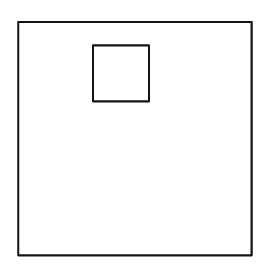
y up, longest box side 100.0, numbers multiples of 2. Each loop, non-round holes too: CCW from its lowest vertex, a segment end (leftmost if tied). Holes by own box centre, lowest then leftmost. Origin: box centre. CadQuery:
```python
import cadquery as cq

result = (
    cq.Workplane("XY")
    .moveTo(-50.0, -50.0)
    .lineTo(50.0, -50.0)
    .lineTo(50.0, 50.0)
    .lineTo(-50.0, 50.0)
    .close()
    .moveTo(-18.0, 16.0)
    .lineTo(6.0, 16.0)
    .lineTo(6.0, 40.0)
    .lineTo(-18.0, 40.0)
    .close()
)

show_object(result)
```